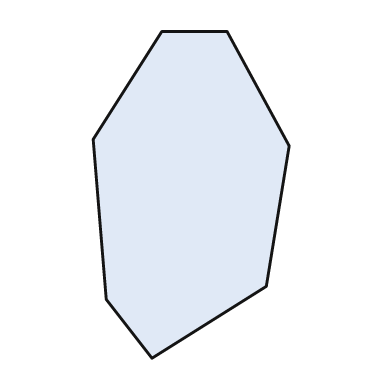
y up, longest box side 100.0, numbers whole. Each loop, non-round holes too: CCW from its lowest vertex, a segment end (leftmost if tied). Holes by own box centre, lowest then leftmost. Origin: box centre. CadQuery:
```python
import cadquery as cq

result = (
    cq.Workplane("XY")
    .moveTo(-12.0, -50.0)
    .lineTo(23.0, -28.0)
    .lineTo(30.0, 15.0)
    .lineTo(11.0, 50.0)
    .lineTo(-9.0, 50.0)
    .lineTo(-30.0, 17.0)
    .lineTo(-26.0, -32.0)
    .close()
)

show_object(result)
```